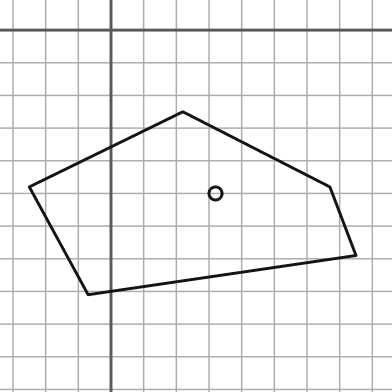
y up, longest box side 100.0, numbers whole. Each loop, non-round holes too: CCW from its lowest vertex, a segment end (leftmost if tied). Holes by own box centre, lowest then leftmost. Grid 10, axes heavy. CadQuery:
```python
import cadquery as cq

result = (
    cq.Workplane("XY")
    .moveTo(-7.0, -81.0)
    .lineTo(75.0, -69.0)
    .lineTo(67.0, -48.0)
    .lineTo(22.0, -25.0)
    .lineTo(-25.0, -48.0)
    .close()
    .moveTo(32.0, -50.0)
    .circle(2.0)
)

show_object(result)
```